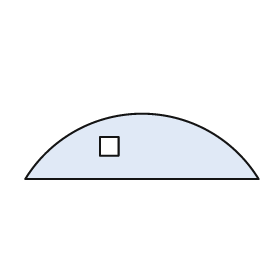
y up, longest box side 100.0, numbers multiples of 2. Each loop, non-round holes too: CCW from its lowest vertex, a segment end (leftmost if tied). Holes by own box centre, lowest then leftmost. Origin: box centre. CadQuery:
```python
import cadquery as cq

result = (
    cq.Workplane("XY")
    .moveTo(-50.0, -14.0)
    .lineTo(50.0, -14.0)
    .threePointArc((0.0, 14.0), (-50.0, -14.0))
    .close()
    .moveTo(-18.0, -4.0)
    .lineTo(-10.0, -4.0)
    .lineTo(-10.0, 4.0)
    .lineTo(-18.0, 4.0)
    .close()
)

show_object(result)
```